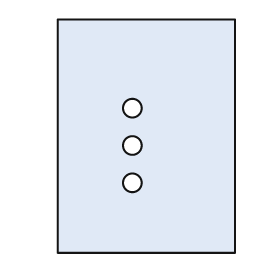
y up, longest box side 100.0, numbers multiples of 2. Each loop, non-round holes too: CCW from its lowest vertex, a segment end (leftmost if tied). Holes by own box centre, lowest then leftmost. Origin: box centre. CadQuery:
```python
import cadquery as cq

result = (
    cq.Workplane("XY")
    .moveTo(-38.0, -50.0)
    .lineTo(38.0, -50.0)
    .lineTo(38.0, 50.0)
    .lineTo(-38.0, 50.0)
    .close()
    .moveTo(-6.0, -20.0)
    .circle(4.0)
    .moveTo(-6.0, -4.0)
    .circle(4.0)
    .moveTo(-6.0, 12.0)
    .circle(4.0)
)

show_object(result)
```